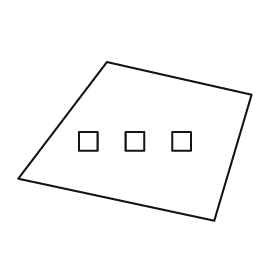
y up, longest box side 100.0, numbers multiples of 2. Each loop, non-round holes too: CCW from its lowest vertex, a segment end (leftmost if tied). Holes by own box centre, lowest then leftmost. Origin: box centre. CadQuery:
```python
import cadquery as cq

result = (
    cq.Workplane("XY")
    .moveTo(34.0, -34.0)
    .lineTo(50.0, 20.0)
    .lineTo(-12.0, 34.0)
    .lineTo(-50.0, -16.0)
    .close()
    .moveTo(-24.0, -4.0)
    .lineTo(-16.0, -4.0)
    .lineTo(-16.0, 4.0)
    .lineTo(-24.0, 4.0)
    .close()
    .moveTo(-4.0, -4.0)
    .lineTo(4.0, -4.0)
    .lineTo(4.0, 4.0)
    .lineTo(-4.0, 4.0)
    .close()
    .moveTo(16.0, -4.0)
    .lineTo(24.0, -4.0)
    .lineTo(24.0, 4.0)
    .lineTo(16.0, 4.0)
    .close()
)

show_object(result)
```